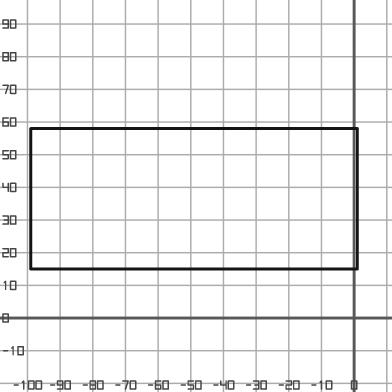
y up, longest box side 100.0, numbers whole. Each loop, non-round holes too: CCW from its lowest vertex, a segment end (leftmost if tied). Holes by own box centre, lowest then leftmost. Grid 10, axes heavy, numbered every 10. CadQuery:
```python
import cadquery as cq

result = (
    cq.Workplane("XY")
    .moveTo(-99.0, 15.0)
    .lineTo(1.0, 15.0)
    .lineTo(1.0, 58.0)
    .lineTo(-99.0, 58.0)
    .close()
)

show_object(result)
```